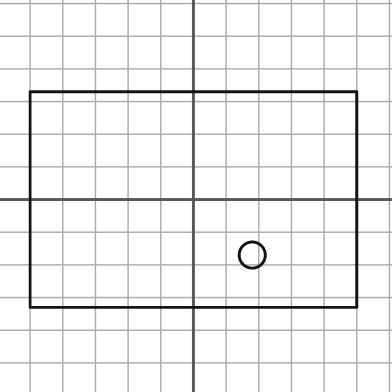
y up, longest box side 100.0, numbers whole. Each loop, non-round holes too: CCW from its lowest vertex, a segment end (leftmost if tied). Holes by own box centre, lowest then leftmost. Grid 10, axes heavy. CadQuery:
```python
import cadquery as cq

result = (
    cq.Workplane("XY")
    .moveTo(-50.0, -33.0)
    .lineTo(50.0, -33.0)
    .lineTo(50.0, 33.0)
    .lineTo(-50.0, 33.0)
    .close()
    .moveTo(18.0, -17.0)
    .circle(4.0)
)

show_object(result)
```